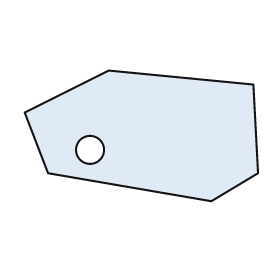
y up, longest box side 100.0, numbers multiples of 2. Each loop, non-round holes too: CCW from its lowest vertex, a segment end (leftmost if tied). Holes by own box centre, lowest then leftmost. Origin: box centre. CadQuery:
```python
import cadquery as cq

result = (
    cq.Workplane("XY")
    .moveTo(30.0, -28.0)
    .lineTo(50.0, -16.0)
    .lineTo(48.0, 22.0)
    .lineTo(-14.0, 28.0)
    .lineTo(-50.0, 10.0)
    .lineTo(-40.0, -16.0)
    .close()
    .moveTo(-22.0, -6.0)
    .circle(6.0)
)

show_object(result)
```